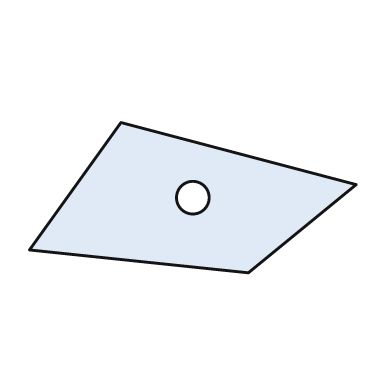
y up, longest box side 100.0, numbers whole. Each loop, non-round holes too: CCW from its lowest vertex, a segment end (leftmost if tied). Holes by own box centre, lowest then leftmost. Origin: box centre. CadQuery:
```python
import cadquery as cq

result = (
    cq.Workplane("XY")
    .moveTo(17.0, -23.0)
    .lineTo(50.0, 4.0)
    .lineTo(-22.0, 23.0)
    .lineTo(-50.0, -16.0)
    .close()
    .moveTo(0.0, 0.0)
    .circle(5.0)
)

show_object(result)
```